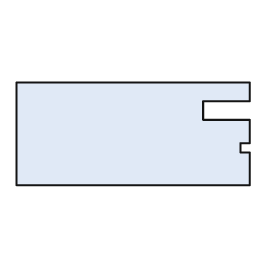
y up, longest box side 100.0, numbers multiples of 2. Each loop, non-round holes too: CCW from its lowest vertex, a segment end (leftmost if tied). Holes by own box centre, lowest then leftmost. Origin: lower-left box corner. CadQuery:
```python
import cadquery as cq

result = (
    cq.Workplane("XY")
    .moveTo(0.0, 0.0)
    .lineTo(100.0, 0.0)
    .lineTo(100.0, 14.0)
    .lineTo(96.0, 14.0)
    .lineTo(96.0, 18.0)
    .lineTo(100.0, 18.0)
    .lineTo(100.0, 28.0)
    .lineTo(80.0, 28.0)
    .lineTo(80.0, 36.0)
    .lineTo(100.0, 36.0)
    .lineTo(100.0, 44.0)
    .lineTo(0.0, 44.0)
    .close()
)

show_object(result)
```